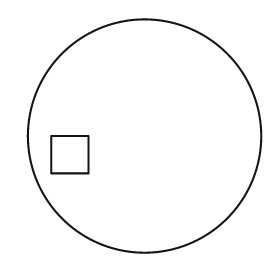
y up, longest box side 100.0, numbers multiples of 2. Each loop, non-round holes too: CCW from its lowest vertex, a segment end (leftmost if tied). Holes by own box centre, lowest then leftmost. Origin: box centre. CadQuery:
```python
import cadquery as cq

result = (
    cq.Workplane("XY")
    .moveTo(0.0, 0.0)
    .circle(50.0)
    .moveTo(-40.0, -16.0)
    .lineTo(-24.0, -16.0)
    .lineTo(-24.0, 0.0)
    .lineTo(-40.0, 0.0)
    .close()
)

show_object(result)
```